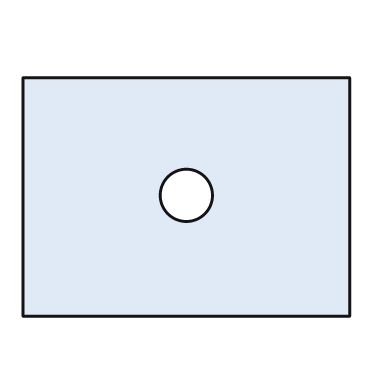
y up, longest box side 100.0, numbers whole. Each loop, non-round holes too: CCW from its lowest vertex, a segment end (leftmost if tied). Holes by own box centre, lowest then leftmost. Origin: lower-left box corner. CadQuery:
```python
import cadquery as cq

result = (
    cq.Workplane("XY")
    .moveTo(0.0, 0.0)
    .lineTo(100.0, 0.0)
    .lineTo(100.0, 73.0)
    .lineTo(0.0, 73.0)
    .close()
    .moveTo(50.0, 37.0)
    .circle(8.0)
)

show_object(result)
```